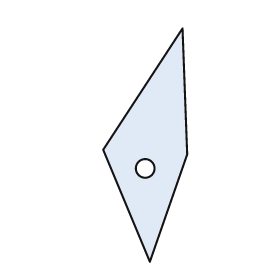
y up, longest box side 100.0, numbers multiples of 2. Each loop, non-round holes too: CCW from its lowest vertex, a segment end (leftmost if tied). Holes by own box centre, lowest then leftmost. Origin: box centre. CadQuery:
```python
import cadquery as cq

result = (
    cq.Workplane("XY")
    .moveTo(2.0, -50.0)
    .lineTo(18.0, -4.0)
    .lineTo(16.0, 50.0)
    .lineTo(-18.0, -2.0)
    .close()
    .moveTo(0.0, -10.0)
    .circle(4.0)
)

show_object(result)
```